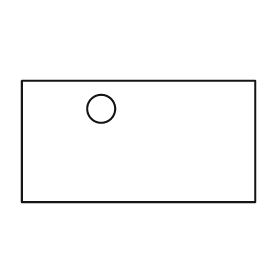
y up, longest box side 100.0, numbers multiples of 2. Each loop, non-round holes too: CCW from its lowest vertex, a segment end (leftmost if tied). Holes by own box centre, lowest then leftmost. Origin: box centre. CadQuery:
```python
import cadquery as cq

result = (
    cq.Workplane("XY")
    .moveTo(-50.0, -26.0)
    .lineTo(50.0, -26.0)
    .lineTo(50.0, 26.0)
    .lineTo(-50.0, 26.0)
    .close()
    .moveTo(-16.0, 14.0)
    .circle(6.0)
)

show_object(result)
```